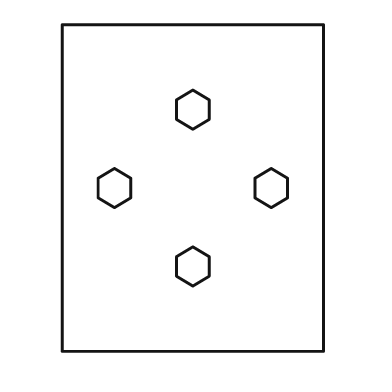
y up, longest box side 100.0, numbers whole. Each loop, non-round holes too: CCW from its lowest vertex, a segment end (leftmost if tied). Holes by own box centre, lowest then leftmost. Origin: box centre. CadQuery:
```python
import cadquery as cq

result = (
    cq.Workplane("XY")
    .moveTo(-40.0, -50.0)
    .lineTo(40.0, -50.0)
    .lineTo(40.0, 50.0)
    .lineTo(-40.0, 50.0)
    .close()
    .moveTo(0.0, -30.0)
    .lineTo(5.0, -27.0)
    .lineTo(5.0, -21.0)
    .lineTo(0.0, -18.0)
    .lineTo(-5.0, -21.0)
    .lineTo(-5.0, -27.0)
    .close()
    .moveTo(-24.0, -6.0)
    .lineTo(-19.0, -3.0)
    .lineTo(-19.0, 3.0)
    .lineTo(-24.0, 6.0)
    .lineTo(-29.0, 3.0)
    .lineTo(-29.0, -3.0)
    .close()
    .moveTo(24.0, -6.0)
    .lineTo(29.0, -3.0)
    .lineTo(29.0, 3.0)
    .lineTo(24.0, 6.0)
    .lineTo(19.0, 3.0)
    .lineTo(19.0, -3.0)
    .close()
    .moveTo(0.0, 18.0)
    .lineTo(5.0, 21.0)
    .lineTo(5.0, 27.0)
    .lineTo(0.0, 30.0)
    .lineTo(-5.0, 27.0)
    .lineTo(-5.0, 21.0)
    .close()
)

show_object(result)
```